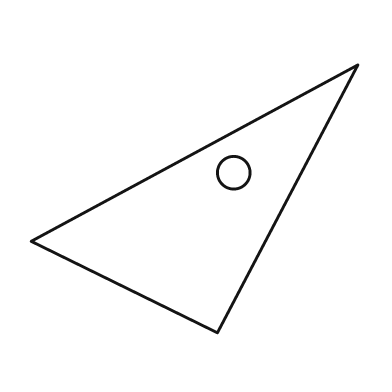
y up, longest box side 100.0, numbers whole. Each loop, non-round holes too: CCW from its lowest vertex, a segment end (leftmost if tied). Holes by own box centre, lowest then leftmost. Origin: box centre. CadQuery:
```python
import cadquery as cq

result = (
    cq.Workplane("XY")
    .moveTo(7.0, -41.0)
    .lineTo(50.0, 41.0)
    .lineTo(-50.0, -13.0)
    .close()
    .moveTo(12.0, 8.0)
    .circle(5.0)
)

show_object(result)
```